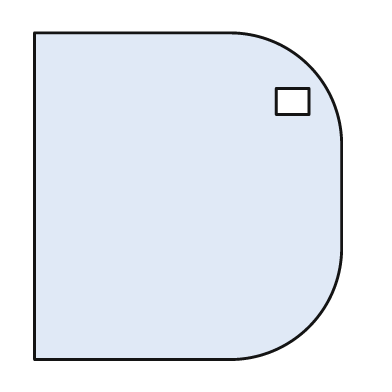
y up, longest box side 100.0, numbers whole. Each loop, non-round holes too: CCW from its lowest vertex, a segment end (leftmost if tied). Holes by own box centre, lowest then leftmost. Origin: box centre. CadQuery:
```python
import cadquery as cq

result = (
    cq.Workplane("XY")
    .moveTo(-47.0, -50.0)
    .lineTo(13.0, -50.0)
    .threePointArc((37.0, -40.0), (47.0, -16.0))
    .lineTo(47.0, 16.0)
    .threePointArc((37.0, 40.0), (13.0, 50.0))
    .lineTo(-47.0, 50.0)
    .close()
    .moveTo(27.0, 25.0)
    .lineTo(37.0, 25.0)
    .lineTo(37.0, 33.0)
    .lineTo(27.0, 33.0)
    .close()
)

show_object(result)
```